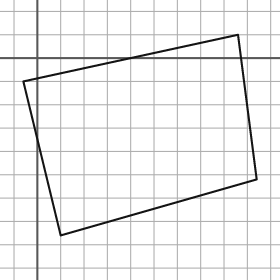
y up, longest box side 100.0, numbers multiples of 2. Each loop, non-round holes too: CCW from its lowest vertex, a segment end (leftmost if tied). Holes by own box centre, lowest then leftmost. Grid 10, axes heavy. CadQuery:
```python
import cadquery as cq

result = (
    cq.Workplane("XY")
    .moveTo(10.0, -76.0)
    .lineTo(94.0, -52.0)
    .lineTo(86.0, 10.0)
    .lineTo(-6.0, -10.0)
    .close()
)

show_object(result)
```